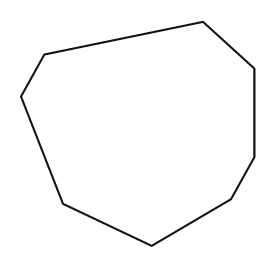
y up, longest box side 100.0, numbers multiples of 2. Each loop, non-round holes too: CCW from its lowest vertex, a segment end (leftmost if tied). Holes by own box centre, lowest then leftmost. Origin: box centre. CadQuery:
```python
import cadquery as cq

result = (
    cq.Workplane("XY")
    .moveTo(6.0, -48.0)
    .lineTo(40.0, -28.0)
    .lineTo(50.0, -10.0)
    .lineTo(50.0, 28.0)
    .lineTo(28.0, 48.0)
    .lineTo(-40.0, 34.0)
    .lineTo(-50.0, 16.0)
    .lineTo(-32.0, -30.0)
    .close()
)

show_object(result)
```